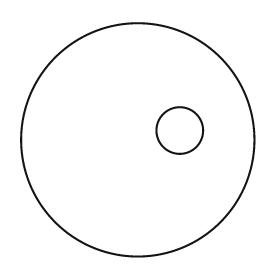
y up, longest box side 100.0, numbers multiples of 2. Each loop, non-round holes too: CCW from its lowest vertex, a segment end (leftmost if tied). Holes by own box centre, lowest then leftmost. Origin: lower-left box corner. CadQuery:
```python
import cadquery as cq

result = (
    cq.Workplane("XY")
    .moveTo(50.0, 50.0)
    .circle(50.0)
    .moveTo(68.0, 54.0)
    .circle(10.0)
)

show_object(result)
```